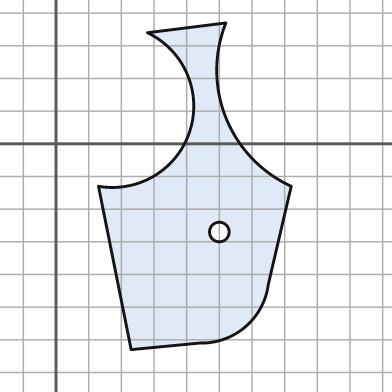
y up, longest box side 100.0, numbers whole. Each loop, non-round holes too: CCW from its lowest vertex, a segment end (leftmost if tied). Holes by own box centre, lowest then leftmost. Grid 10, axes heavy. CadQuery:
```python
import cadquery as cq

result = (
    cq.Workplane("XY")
    .moveTo(23.0, -63.0)
    .lineTo(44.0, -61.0)
    .threePointArc((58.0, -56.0), (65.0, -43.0))
    .lineTo(72.0, -13.0)
    .threePointArc((52.0, 8.0), (52.0, 37.0))
    .lineTo(28.0, 34.0)
    .threePointArc((41.0, 4.0), (13.0, -13.0))
    .close()
    .moveTo(50.0, -27.0)
    .circle(3.0)
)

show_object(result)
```